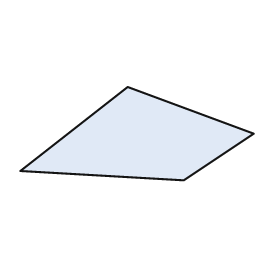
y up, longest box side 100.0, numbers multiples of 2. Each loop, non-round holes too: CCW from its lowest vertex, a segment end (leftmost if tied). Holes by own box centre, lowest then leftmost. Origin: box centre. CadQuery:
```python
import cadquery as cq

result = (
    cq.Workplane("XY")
    .moveTo(20.0, -20.0)
    .lineTo(50.0, 0.0)
    .lineTo(-4.0, 20.0)
    .lineTo(-50.0, -16.0)
    .close()
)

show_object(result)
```